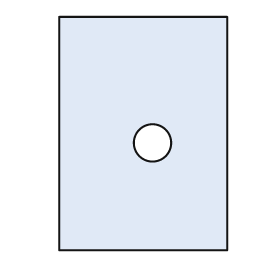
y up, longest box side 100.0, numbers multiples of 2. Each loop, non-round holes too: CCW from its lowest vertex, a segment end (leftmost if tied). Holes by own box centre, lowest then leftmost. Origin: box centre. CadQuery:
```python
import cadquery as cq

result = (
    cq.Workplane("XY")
    .moveTo(-36.0, -50.0)
    .lineTo(36.0, -50.0)
    .lineTo(36.0, 50.0)
    .lineTo(-36.0, 50.0)
    .close()
    .moveTo(4.0, -4.0)
    .circle(8.0)
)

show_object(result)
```